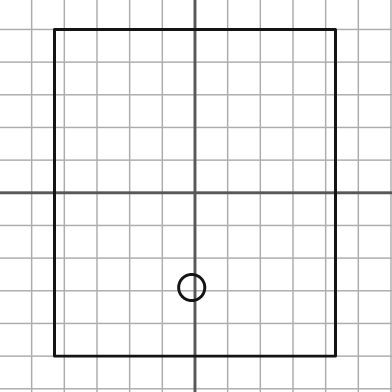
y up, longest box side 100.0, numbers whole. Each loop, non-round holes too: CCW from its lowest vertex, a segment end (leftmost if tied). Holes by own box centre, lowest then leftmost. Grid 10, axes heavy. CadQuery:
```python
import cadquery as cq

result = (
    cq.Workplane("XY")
    .moveTo(-43.0, -50.0)
    .lineTo(43.0, -50.0)
    .lineTo(43.0, 50.0)
    .lineTo(-43.0, 50.0)
    .close()
    .moveTo(-1.0, -29.0)
    .circle(4.0)
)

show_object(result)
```